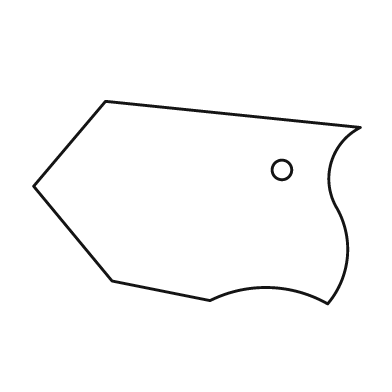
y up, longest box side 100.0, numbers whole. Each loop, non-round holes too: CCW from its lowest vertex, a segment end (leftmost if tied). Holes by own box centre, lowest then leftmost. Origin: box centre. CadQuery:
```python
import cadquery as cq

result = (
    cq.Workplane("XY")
    .moveTo(40.0, -31.0)
    .threePointArc((46.0, -17.0), (43.0, -2.0))
    .threePointArc((41.0, 12.0), (50.0, 23.0))
    .lineTo(-28.0, 31.0)
    .lineTo(-50.0, 5.0)
    .lineTo(-26.0, -24.0)
    .lineTo(4.0, -30.0)
    .threePointArc((22.0, -26.0), (40.0, -31.0))
    .close()
    .moveTo(26.0, 10.0)
    .circle(3.0)
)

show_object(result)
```